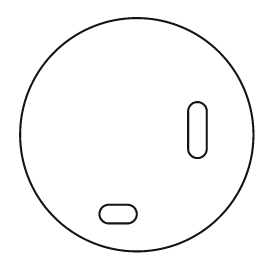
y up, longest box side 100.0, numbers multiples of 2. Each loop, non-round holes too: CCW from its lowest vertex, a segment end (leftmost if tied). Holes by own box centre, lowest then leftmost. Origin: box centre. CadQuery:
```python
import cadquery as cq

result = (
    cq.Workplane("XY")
    .moveTo(0.0, 0.0)
    .circle(50.0)
    .moveTo(-12.0, -38.0)
    .lineTo(-4.0, -38.0)
    .threePointArc((0.0, -34.0), (-4.0, -30.0))
    .lineTo(-12.0, -30.0)
    .threePointArc((-16.0, -34.0), (-12.0, -38.0))
    .close()
    .moveTo(22.0, -6.0)
    .threePointArc((26.0, -10.0), (30.0, -6.0))
    .lineTo(30.0, 10.0)
    .threePointArc((26.0, 14.0), (22.0, 10.0))
    .close()
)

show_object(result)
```